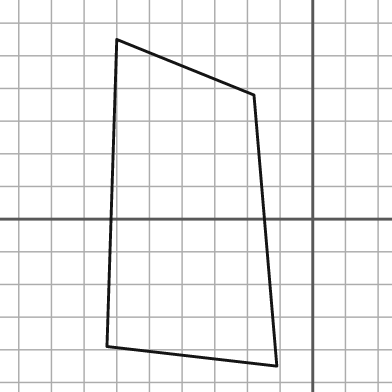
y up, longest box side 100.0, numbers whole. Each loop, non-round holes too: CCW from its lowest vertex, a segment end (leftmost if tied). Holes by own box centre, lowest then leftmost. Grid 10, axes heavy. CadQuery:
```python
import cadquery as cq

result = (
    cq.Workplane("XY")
    .moveTo(-11.0, -45.0)
    .lineTo(-18.0, 38.0)
    .lineTo(-60.0, 55.0)
    .lineTo(-63.0, -39.0)
    .close()
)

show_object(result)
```